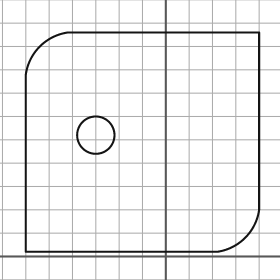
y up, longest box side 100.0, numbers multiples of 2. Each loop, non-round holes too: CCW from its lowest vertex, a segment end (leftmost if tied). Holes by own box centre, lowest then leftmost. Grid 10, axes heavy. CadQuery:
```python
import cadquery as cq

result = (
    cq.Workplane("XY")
    .moveTo(-60.0, 2.0)
    .lineTo(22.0, 2.0)
    .threePointArc((34.0, 8.0), (40.0, 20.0))
    .lineTo(40.0, 96.0)
    .lineTo(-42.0, 96.0)
    .threePointArc((-54.0, 90.0), (-60.0, 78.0))
    .close()
    .moveTo(-30.0, 52.0)
    .circle(8.0)
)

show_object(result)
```